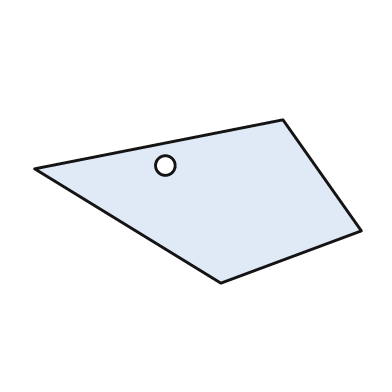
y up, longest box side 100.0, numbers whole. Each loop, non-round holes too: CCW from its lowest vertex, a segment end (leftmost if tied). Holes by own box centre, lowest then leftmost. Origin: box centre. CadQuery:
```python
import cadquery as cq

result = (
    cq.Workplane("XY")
    .moveTo(7.0, -25.0)
    .lineTo(50.0, -9.0)
    .lineTo(26.0, 25.0)
    .lineTo(-50.0, 10.0)
    .close()
    .moveTo(-10.0, 11.0)
    .circle(3.0)
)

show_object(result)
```